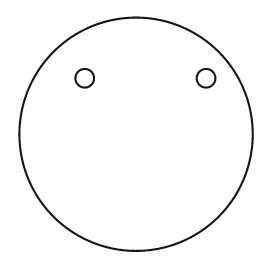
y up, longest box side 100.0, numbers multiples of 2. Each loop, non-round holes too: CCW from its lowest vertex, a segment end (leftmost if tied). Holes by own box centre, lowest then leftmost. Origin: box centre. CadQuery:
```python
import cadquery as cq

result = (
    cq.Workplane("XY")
    .moveTo(0.0, 0.0)
    .circle(50.0)
    .moveTo(-22.0, 24.0)
    .circle(4.0)
    .moveTo(30.0, 24.0)
    .circle(4.0)
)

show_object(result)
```